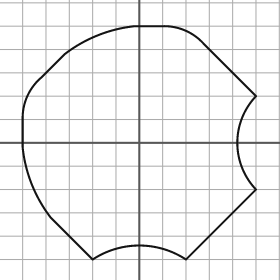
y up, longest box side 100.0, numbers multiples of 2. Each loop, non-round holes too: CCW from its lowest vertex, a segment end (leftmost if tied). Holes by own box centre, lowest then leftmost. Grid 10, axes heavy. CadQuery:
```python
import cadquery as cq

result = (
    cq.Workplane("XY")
    .moveTo(-20.0, -50.0)
    .threePointArc((0.0, -44.0), (20.0, -50.0))
    .lineTo(50.0, -20.0)
    .threePointArc((42.0, 0.0), (50.0, 20.0))
    .lineTo(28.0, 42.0)
    .threePointArc((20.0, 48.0), (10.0, 50.0))
    .lineTo(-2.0, 50.0)
    .threePointArc((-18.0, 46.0), (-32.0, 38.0))
    .lineTo(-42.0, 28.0)
    .threePointArc((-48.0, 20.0), (-50.0, 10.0))
    .lineTo(-50.0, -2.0)
    .threePointArc((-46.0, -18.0), (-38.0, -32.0))
    .close()
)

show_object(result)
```